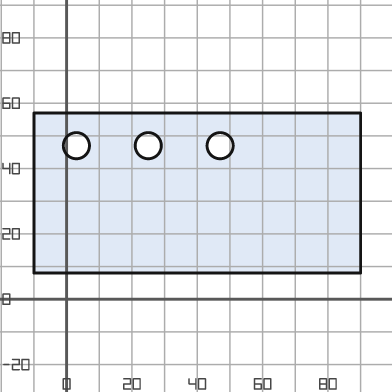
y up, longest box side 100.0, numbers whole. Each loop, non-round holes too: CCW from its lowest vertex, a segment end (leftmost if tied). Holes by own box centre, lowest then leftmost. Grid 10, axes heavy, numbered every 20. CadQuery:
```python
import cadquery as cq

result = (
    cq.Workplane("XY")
    .moveTo(-10.0, 8.0)
    .lineTo(90.0, 8.0)
    .lineTo(90.0, 57.0)
    .lineTo(-10.0, 57.0)
    .close()
    .moveTo(3.0, 47.0)
    .circle(4.0)
    .moveTo(25.0, 47.0)
    .circle(4.0)
    .moveTo(47.0, 47.0)
    .circle(4.0)
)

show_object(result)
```